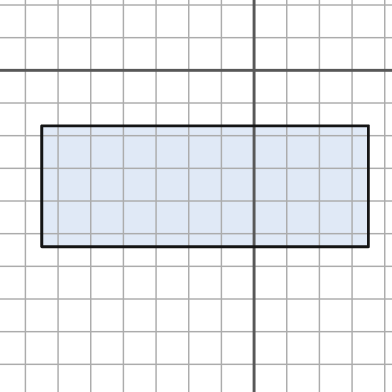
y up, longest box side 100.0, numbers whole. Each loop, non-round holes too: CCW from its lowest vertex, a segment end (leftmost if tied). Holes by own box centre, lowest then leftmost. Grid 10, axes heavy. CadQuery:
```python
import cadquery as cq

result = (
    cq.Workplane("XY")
    .moveTo(-65.0, -54.0)
    .lineTo(35.0, -54.0)
    .lineTo(35.0, -17.0)
    .lineTo(-65.0, -17.0)
    .close()
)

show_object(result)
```